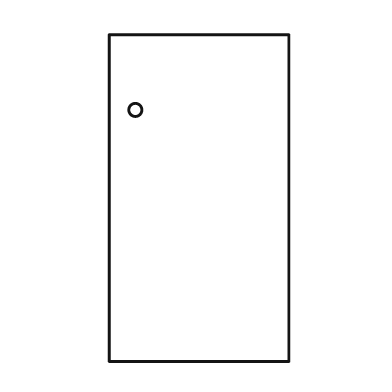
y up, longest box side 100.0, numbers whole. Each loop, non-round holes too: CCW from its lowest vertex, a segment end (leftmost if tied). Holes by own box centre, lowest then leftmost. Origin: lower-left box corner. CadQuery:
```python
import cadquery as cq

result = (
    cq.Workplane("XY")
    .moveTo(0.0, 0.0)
    .lineTo(55.0, 0.0)
    .lineTo(55.0, 100.0)
    .lineTo(0.0, 100.0)
    .close()
    .moveTo(8.0, 77.0)
    .circle(2.0)
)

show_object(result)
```